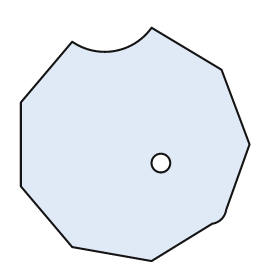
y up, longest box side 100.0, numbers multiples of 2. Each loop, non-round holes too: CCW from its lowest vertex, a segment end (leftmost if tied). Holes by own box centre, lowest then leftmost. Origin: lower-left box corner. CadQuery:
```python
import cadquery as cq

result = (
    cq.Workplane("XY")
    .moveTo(56.0, 0.0)
    .lineTo(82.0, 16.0)
    .threePointArc((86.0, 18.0), (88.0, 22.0))
    .lineTo(98.0, 50.0)
    .lineTo(86.0, 82.0)
    .lineTo(56.0, 100.0)
    .threePointArc((40.0, 90.0), (22.0, 94.0))
    .lineTo(0.0, 68.0)
    .lineTo(0.0, 32.0)
    .lineTo(22.0, 6.0)
    .close()
    .moveTo(60.0, 42.0)
    .circle(4.0)
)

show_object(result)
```